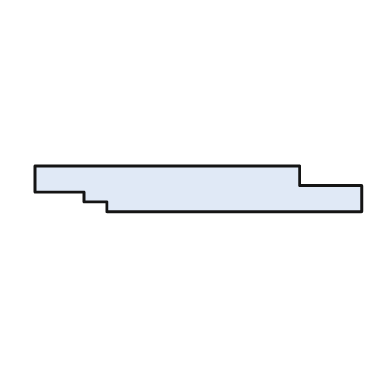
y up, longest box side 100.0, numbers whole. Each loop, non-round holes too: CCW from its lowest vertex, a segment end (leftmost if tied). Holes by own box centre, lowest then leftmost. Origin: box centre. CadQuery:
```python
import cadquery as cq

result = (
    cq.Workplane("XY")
    .moveTo(-28.0, -7.0)
    .lineTo(50.0, -7.0)
    .lineTo(50.0, 1.0)
    .lineTo(31.0, 1.0)
    .lineTo(31.0, 7.0)
    .lineTo(-50.0, 7.0)
    .lineTo(-50.0, -1.0)
    .lineTo(-35.0, -1.0)
    .lineTo(-35.0, -4.0)
    .lineTo(-28.0, -4.0)
    .close()
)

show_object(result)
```